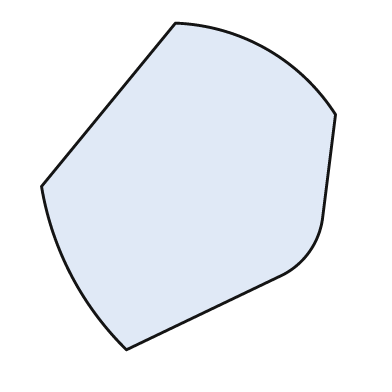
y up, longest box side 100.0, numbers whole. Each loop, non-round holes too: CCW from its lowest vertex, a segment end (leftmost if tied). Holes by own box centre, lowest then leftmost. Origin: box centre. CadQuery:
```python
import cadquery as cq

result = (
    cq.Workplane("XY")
    .moveTo(-19.0, -50.0)
    .lineTo(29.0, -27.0)
    .threePointArc((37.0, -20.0), (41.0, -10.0))
    .lineTo(45.0, 22.0)
    .threePointArc((24.0, 42.0), (-4.0, 50.0))
    .lineTo(-45.0, 0.0)
    .threePointArc((-36.0, -27.0), (-19.0, -50.0))
    .close()
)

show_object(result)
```